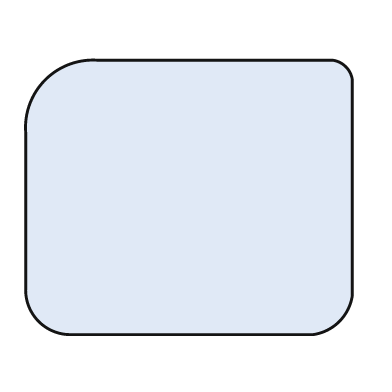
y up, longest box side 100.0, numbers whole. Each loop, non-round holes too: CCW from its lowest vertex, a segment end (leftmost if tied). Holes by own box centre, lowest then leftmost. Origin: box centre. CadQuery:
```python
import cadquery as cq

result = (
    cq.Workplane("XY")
    .moveTo(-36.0, -42.0)
    .lineTo(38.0, -42.0)
    .threePointArc((46.0, -38.0), (50.0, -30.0))
    .lineTo(50.0, 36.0)
    .threePointArc((48.0, 40.0), (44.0, 42.0))
    .lineTo(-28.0, 42.0)
    .threePointArc((-44.0, 36.0), (-50.0, 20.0))
    .lineTo(-50.0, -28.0)
    .threePointArc((-46.0, -38.0), (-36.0, -42.0))
    .close()
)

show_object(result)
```